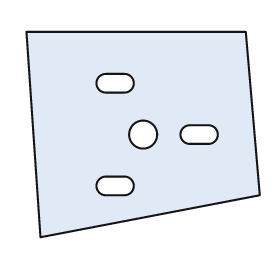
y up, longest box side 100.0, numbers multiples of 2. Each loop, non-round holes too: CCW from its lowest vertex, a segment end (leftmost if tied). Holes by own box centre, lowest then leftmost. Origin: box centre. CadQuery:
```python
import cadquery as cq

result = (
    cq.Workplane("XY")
    .moveTo(-44.0, -44.0)
    .lineTo(50.0, -26.0)
    .lineTo(44.0, 44.0)
    .lineTo(-50.0, 44.0)
    .close()
    .moveTo(-16.0, -26.0)
    .lineTo(-8.0, -26.0)
    .threePointArc((-4.0, -22.0), (-8.0, -18.0))
    .lineTo(-16.0, -18.0)
    .threePointArc((-20.0, -22.0), (-16.0, -26.0))
    .close()
    .moveTo(0.0, 0.0)
    .circle(6.0)
    .moveTo(20.0, -4.0)
    .lineTo(28.0, -4.0)
    .threePointArc((32.0, 0.0), (28.0, 4.0))
    .lineTo(20.0, 4.0)
    .threePointArc((16.0, 0.0), (20.0, -4.0))
    .close()
    .moveTo(-16.0, 18.0)
    .lineTo(-8.0, 18.0)
    .threePointArc((-4.0, 22.0), (-8.0, 26.0))
    .lineTo(-16.0, 26.0)
    .threePointArc((-20.0, 22.0), (-16.0, 18.0))
    .close()
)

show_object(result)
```